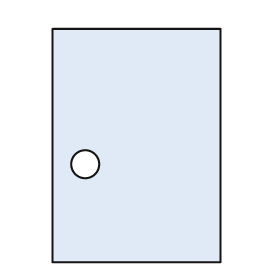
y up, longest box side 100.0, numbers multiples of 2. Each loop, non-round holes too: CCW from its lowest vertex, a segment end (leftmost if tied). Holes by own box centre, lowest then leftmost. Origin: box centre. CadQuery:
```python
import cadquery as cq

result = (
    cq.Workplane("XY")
    .moveTo(-36.0, -50.0)
    .lineTo(36.0, -50.0)
    .lineTo(36.0, 50.0)
    .lineTo(-36.0, 50.0)
    .close()
    .moveTo(-22.0, -8.0)
    .circle(6.0)
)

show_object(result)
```